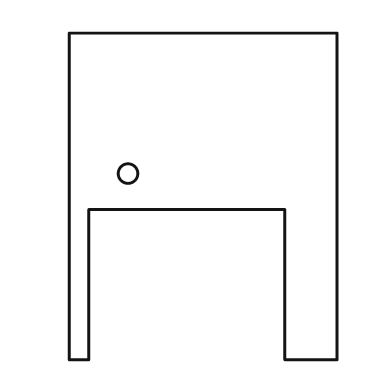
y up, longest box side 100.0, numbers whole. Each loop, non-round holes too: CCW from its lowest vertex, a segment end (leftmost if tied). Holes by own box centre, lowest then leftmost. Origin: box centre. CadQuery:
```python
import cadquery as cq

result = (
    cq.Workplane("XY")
    .moveTo(-41.0, -50.0)
    .lineTo(-35.0, -50.0)
    .lineTo(-35.0, -4.0)
    .lineTo(25.0, -4.0)
    .lineTo(25.0, -50.0)
    .lineTo(41.0, -50.0)
    .lineTo(41.0, 50.0)
    .lineTo(-41.0, 50.0)
    .close()
    .moveTo(-23.0, 7.0)
    .circle(3.0)
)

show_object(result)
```